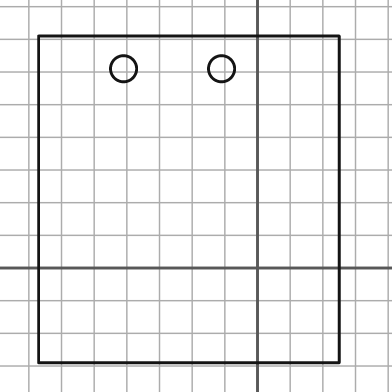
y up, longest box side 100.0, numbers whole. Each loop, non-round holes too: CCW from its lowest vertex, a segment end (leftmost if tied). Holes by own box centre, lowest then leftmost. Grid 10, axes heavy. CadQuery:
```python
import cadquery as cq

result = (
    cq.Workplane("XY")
    .moveTo(-67.0, -29.0)
    .lineTo(25.0, -29.0)
    .lineTo(25.0, 71.0)
    .lineTo(-67.0, 71.0)
    .close()
    .moveTo(-41.0, 61.0)
    .circle(4.0)
    .moveTo(-11.0, 61.0)
    .circle(4.0)
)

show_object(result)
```